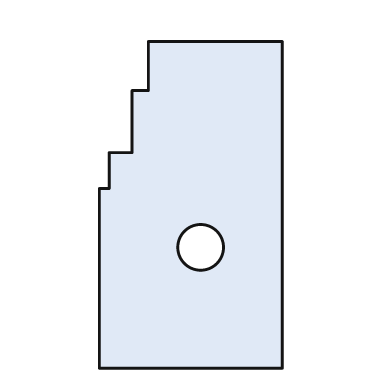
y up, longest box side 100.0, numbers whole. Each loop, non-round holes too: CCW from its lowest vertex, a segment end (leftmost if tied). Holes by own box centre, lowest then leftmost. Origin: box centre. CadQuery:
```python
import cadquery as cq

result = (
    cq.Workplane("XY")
    .moveTo(-28.0, -50.0)
    .lineTo(28.0, -50.0)
    .lineTo(28.0, 50.0)
    .lineTo(-13.0, 50.0)
    .lineTo(-13.0, 35.0)
    .lineTo(-18.0, 35.0)
    .lineTo(-18.0, 16.0)
    .lineTo(-25.0, 16.0)
    .lineTo(-25.0, 5.0)
    .lineTo(-28.0, 5.0)
    .close()
    .moveTo(3.0, -13.0)
    .circle(7.0)
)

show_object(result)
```